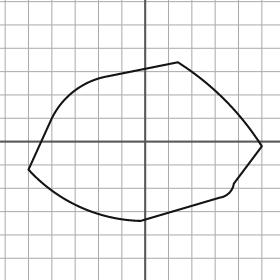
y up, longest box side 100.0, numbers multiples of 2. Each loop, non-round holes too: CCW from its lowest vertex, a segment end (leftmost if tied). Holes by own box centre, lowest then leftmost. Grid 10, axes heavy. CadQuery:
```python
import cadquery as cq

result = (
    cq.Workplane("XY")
    .moveTo(-2.0, -34.0)
    .lineTo(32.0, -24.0)
    .threePointArc((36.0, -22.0), (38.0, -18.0))
    .lineTo(50.0, -2.0)
    .threePointArc((34.0, 18.0), (14.0, 34.0))
    .lineTo(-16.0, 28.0)
    .threePointArc((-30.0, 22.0), (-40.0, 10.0))
    .lineTo(-50.0, -12.0)
    .threePointArc((-28.0, -28.0), (-2.0, -34.0))
    .close()
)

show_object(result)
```